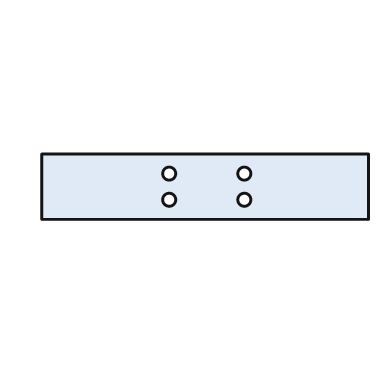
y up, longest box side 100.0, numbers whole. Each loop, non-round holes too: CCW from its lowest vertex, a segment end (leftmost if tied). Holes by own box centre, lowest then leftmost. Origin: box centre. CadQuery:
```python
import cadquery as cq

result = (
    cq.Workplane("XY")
    .moveTo(-50.0, -10.0)
    .lineTo(50.0, -10.0)
    .lineTo(50.0, 10.0)
    .lineTo(-50.0, 10.0)
    .close()
    .moveTo(-11.0, -4.0)
    .circle(2.0)
    .moveTo(12.0, -4.0)
    .circle(2.0)
    .moveTo(-11.0, 4.0)
    .circle(2.0)
    .moveTo(12.0, 4.0)
    .circle(2.0)
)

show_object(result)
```